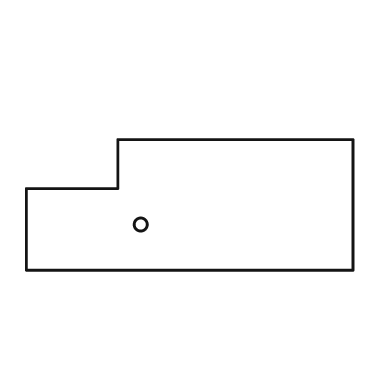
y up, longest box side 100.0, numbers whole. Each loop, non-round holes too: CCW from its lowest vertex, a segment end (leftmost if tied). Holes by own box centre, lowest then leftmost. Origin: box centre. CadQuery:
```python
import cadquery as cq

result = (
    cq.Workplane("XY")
    .moveTo(-50.0, -20.0)
    .lineTo(50.0, -20.0)
    .lineTo(50.0, 20.0)
    .lineTo(-22.0, 20.0)
    .lineTo(-22.0, 5.0)
    .lineTo(-50.0, 5.0)
    .close()
    .moveTo(-15.0, -6.0)
    .circle(2.0)
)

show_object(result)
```